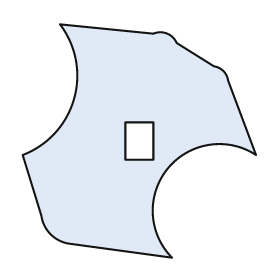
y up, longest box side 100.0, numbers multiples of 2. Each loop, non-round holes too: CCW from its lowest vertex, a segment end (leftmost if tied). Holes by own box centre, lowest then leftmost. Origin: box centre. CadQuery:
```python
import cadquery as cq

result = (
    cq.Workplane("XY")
    .moveTo(14.0, -50.0)
    .threePointArc((12.0, -12.0), (50.0, -6.0))
    .lineTo(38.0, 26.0)
    .threePointArc((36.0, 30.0), (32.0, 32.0))
    .lineTo(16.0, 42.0)
    .threePointArc((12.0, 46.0), (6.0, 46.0))
    .lineTo(-34.0, 50.0)
    .threePointArc((-28.0, 18.0), (-50.0, -6.0))
    .lineTo(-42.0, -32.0)
    .threePointArc((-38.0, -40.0), (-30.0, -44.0))
    .close()
    .moveTo(-6.0, -8.0)
    .lineTo(6.0, -8.0)
    .lineTo(6.0, 8.0)
    .lineTo(-6.0, 8.0)
    .close()
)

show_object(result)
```